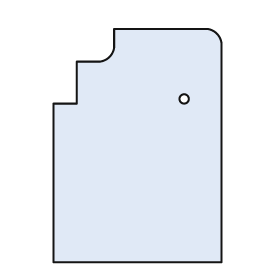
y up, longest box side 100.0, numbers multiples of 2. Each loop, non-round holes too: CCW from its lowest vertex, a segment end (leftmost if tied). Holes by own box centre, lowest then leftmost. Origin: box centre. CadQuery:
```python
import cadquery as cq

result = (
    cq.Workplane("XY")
    .moveTo(-36.0, -50.0)
    .lineTo(36.0, -50.0)
    .lineTo(36.0, 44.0)
    .threePointArc((34.0, 48.0), (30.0, 50.0))
    .lineTo(-10.0, 50.0)
    .lineTo(-10.0, 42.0)
    .threePointArc((-12.0, 38.0), (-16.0, 36.0))
    .lineTo(-26.0, 36.0)
    .lineTo(-26.0, 18.0)
    .lineTo(-36.0, 18.0)
    .close()
    .moveTo(20.0, 20.0)
    .circle(2.0)
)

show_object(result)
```